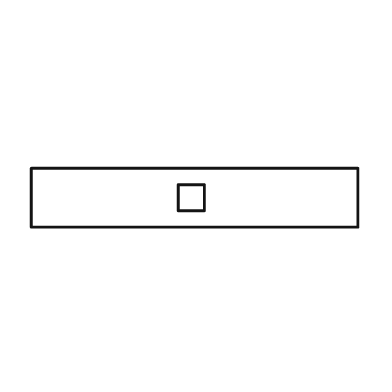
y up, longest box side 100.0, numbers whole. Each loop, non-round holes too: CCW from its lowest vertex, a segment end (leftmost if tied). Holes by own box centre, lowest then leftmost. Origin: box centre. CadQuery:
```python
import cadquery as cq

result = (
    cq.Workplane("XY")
    .moveTo(-50.0, -9.0)
    .lineTo(50.0, -9.0)
    .lineTo(50.0, 9.0)
    .lineTo(-50.0, 9.0)
    .close()
    .moveTo(-5.0, -4.0)
    .lineTo(3.0, -4.0)
    .lineTo(3.0, 4.0)
    .lineTo(-5.0, 4.0)
    .close()
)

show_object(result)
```